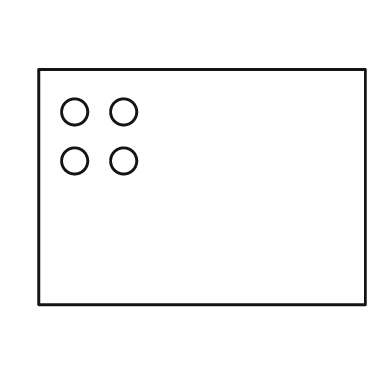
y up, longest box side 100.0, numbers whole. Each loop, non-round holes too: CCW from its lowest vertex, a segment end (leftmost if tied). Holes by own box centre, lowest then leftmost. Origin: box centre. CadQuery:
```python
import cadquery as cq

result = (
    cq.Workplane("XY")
    .moveTo(-50.0, -36.0)
    .lineTo(50.0, -36.0)
    .lineTo(50.0, 36.0)
    .lineTo(-50.0, 36.0)
    .close()
    .moveTo(-39.0, 8.0)
    .circle(4.0)
    .moveTo(-24.0, 8.0)
    .circle(4.0)
    .moveTo(-39.0, 23.0)
    .circle(4.0)
    .moveTo(-24.0, 23.0)
    .circle(4.0)
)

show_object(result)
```